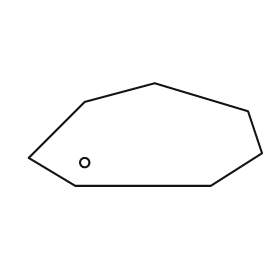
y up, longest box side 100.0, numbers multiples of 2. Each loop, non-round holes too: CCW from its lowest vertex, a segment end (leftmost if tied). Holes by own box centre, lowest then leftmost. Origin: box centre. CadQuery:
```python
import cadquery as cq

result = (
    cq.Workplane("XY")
    .moveTo(-30.0, -22.0)
    .lineTo(28.0, -22.0)
    .lineTo(50.0, -8.0)
    .lineTo(44.0, 10.0)
    .lineTo(4.0, 22.0)
    .lineTo(-26.0, 14.0)
    .lineTo(-50.0, -10.0)
    .close()
    .moveTo(-26.0, -12.0)
    .circle(2.0)
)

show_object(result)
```